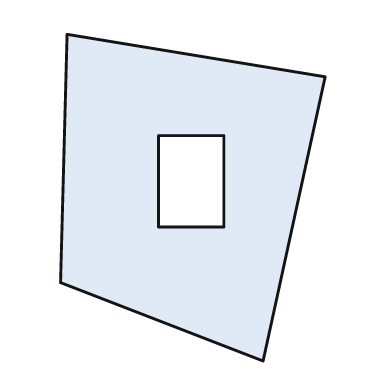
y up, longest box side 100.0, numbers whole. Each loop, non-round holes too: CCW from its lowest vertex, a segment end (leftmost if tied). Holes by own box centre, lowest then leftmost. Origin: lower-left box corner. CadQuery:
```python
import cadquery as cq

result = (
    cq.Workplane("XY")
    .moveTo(62.0, 0.0)
    .lineTo(81.0, 87.0)
    .lineTo(2.0, 100.0)
    .lineTo(0.0, 24.0)
    .close()
    .moveTo(30.0, 41.0)
    .lineTo(50.0, 41.0)
    .lineTo(50.0, 69.0)
    .lineTo(30.0, 69.0)
    .close()
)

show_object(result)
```